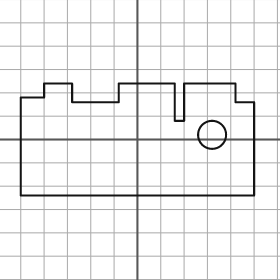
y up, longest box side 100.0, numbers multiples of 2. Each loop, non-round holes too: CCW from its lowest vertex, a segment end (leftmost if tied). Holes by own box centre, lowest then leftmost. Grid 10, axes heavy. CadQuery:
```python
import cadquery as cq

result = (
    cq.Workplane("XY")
    .moveTo(-50.0, -24.0)
    .lineTo(50.0, -24.0)
    .lineTo(50.0, 16.0)
    .lineTo(42.0, 16.0)
    .lineTo(42.0, 24.0)
    .lineTo(20.0, 24.0)
    .lineTo(20.0, 8.0)
    .lineTo(16.0, 8.0)
    .lineTo(16.0, 24.0)
    .lineTo(-8.0, 24.0)
    .lineTo(-8.0, 16.0)
    .lineTo(-28.0, 16.0)
    .lineTo(-28.0, 24.0)
    .lineTo(-40.0, 24.0)
    .lineTo(-40.0, 18.0)
    .lineTo(-50.0, 18.0)
    .close()
    .moveTo(32.0, 2.0)
    .circle(6.0)
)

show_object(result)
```